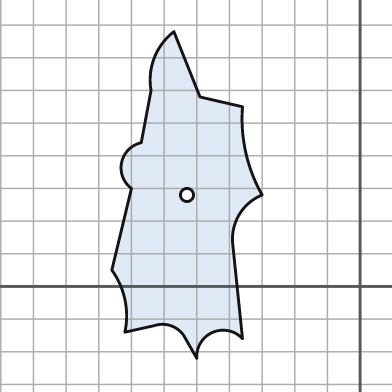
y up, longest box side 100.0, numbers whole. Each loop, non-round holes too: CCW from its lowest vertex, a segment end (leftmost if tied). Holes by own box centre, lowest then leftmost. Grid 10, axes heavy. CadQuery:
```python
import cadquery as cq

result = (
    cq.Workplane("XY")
    .moveTo(-50.0, -22.0)
    .threePointArc((-45.0, -14.0), (-36.0, -16.0))
    .lineTo(-39.0, 13.0)
    .threePointArc((-37.0, 22.0), (-30.0, 28.0))
    .threePointArc((-35.0, 41.0), (-36.0, 55.0))
    .lineTo(-49.0, 58.0)
    .lineTo(-57.0, 78.0)
    .threePointArc((-63.0, 70.0), (-64.0, 60.0))
    .lineTo(-67.0, 44.0)
    .threePointArc((-73.0, 38.0), (-70.0, 30.0))
    .lineTo(-76.0, 5.0)
    .threePointArc((-72.0, -4.0), (-72.0, -14.0))
    .lineTo(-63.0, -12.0)
    .threePointArc((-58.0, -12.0), (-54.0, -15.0))
    .close()
    .moveTo(-53.0, 28.0)
    .circle(2.0)
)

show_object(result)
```